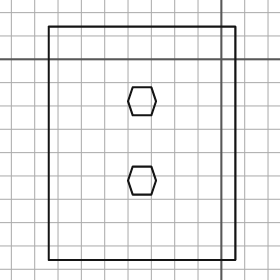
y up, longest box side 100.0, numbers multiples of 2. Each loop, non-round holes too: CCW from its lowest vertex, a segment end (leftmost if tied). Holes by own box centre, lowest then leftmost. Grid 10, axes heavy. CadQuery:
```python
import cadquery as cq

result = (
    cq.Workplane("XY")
    .moveTo(-74.0, -86.0)
    .lineTo(6.0, -86.0)
    .lineTo(6.0, 14.0)
    .lineTo(-74.0, 14.0)
    .close()
    .moveTo(-38.0, -58.0)
    .lineTo(-30.0, -58.0)
    .lineTo(-28.0, -52.0)
    .lineTo(-30.0, -46.0)
    .lineTo(-38.0, -46.0)
    .lineTo(-40.0, -52.0)
    .close()
    .moveTo(-38.0, -24.0)
    .lineTo(-30.0, -24.0)
    .lineTo(-28.0, -18.0)
    .lineTo(-30.0, -12.0)
    .lineTo(-38.0, -12.0)
    .lineTo(-40.0, -18.0)
    .close()
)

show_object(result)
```